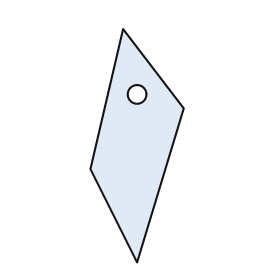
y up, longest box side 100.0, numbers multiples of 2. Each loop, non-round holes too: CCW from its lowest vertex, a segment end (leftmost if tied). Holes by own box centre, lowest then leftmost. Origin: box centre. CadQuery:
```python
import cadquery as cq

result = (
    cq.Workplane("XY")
    .moveTo(0.0, -50.0)
    .lineTo(20.0, 16.0)
    .lineTo(-6.0, 50.0)
    .lineTo(-20.0, -10.0)
    .close()
    .moveTo(0.0, 22.0)
    .circle(4.0)
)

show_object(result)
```